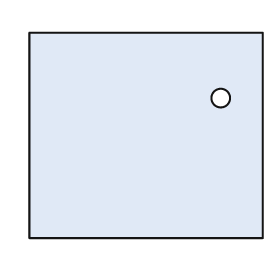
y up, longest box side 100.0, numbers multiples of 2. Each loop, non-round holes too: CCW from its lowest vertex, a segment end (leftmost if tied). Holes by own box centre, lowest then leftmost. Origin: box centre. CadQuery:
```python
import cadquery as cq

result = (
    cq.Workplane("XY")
    .moveTo(-50.0, -44.0)
    .lineTo(50.0, -44.0)
    .lineTo(50.0, 44.0)
    .lineTo(-50.0, 44.0)
    .close()
    .moveTo(32.0, 16.0)
    .circle(4.0)
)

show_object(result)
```